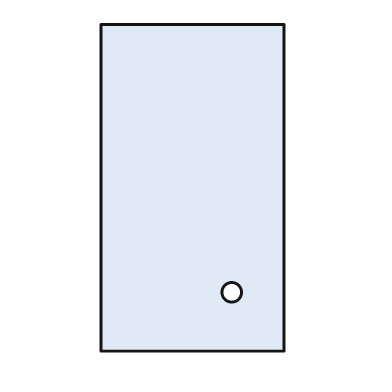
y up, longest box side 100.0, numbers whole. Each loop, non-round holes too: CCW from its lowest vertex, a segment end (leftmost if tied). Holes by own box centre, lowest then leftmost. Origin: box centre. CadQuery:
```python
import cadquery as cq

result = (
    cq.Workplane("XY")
    .moveTo(-28.0, -50.0)
    .lineTo(28.0, -50.0)
    .lineTo(28.0, 50.0)
    .lineTo(-28.0, 50.0)
    .close()
    .moveTo(12.0, -32.0)
    .circle(3.0)
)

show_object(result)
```